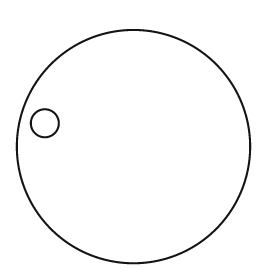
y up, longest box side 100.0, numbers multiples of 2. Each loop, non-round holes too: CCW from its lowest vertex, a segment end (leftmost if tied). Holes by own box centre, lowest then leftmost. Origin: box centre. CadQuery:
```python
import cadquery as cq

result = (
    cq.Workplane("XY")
    .moveTo(0.0, 0.0)
    .circle(50.0)
    .moveTo(-38.0, 10.0)
    .circle(6.0)
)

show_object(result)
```